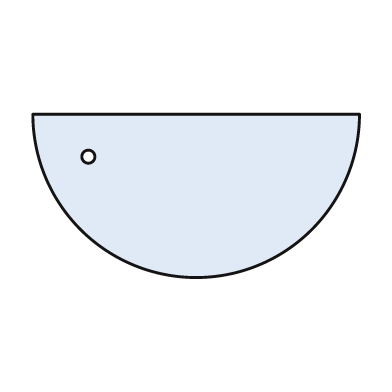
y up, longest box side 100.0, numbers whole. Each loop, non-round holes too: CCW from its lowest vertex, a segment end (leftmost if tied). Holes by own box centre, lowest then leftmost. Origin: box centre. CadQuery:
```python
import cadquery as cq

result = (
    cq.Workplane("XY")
    .moveTo(-50.0, 25.0)
    .threePointArc((0.0, -25.0), (50.0, 25.0))
    .close()
    .moveTo(-33.0, 12.0)
    .circle(2.0)
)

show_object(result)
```